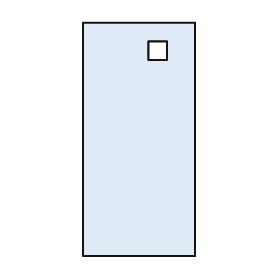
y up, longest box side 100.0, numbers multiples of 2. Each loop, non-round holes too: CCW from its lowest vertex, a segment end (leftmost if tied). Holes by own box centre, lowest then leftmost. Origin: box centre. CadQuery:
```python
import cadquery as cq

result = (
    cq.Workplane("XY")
    .moveTo(-24.0, -50.0)
    .lineTo(24.0, -50.0)
    .lineTo(24.0, 50.0)
    .lineTo(-24.0, 50.0)
    .close()
    .moveTo(4.0, 34.0)
    .lineTo(12.0, 34.0)
    .lineTo(12.0, 42.0)
    .lineTo(4.0, 42.0)
    .close()
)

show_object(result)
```